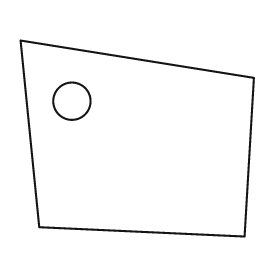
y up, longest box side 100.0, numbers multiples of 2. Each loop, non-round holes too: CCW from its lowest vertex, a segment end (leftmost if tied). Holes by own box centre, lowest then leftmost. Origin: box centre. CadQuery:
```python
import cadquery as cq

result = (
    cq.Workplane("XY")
    .moveTo(46.0, -42.0)
    .lineTo(50.0, 26.0)
    .lineTo(-50.0, 42.0)
    .lineTo(-42.0, -38.0)
    .close()
    .moveTo(-28.0, 16.0)
    .circle(8.0)
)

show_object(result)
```